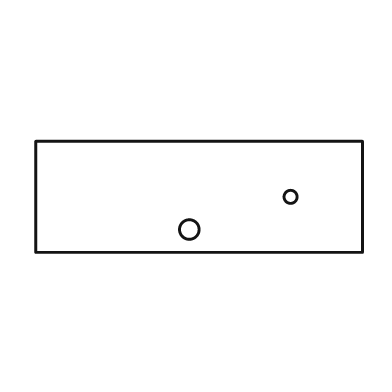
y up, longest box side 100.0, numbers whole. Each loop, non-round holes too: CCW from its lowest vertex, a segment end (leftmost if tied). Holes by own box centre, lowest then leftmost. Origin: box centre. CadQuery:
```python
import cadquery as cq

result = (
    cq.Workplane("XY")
    .moveTo(-50.0, -17.0)
    .lineTo(50.0, -17.0)
    .lineTo(50.0, 17.0)
    .lineTo(-50.0, 17.0)
    .close()
    .moveTo(-3.0, -10.0)
    .circle(3.0)
    .moveTo(28.0, 0.0)
    .circle(2.0)
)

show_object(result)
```